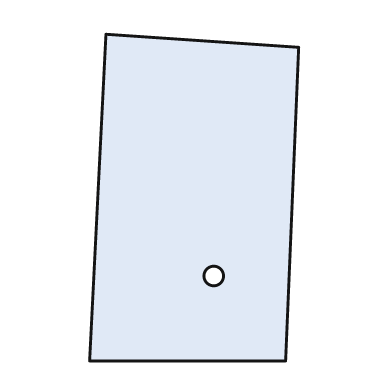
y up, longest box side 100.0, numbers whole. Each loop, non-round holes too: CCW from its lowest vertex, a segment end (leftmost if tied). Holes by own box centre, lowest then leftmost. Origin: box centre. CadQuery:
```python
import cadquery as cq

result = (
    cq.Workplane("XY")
    .moveTo(-32.0, -50.0)
    .lineTo(28.0, -50.0)
    .lineTo(32.0, 46.0)
    .lineTo(-27.0, 50.0)
    .close()
    .moveTo(6.0, -24.0)
    .circle(3.0)
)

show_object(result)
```